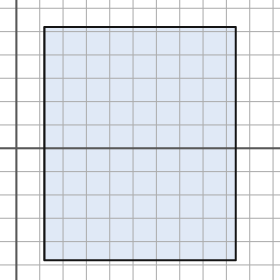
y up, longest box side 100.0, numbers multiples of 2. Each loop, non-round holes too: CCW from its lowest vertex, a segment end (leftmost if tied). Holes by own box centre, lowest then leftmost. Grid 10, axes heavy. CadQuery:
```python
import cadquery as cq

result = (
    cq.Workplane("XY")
    .moveTo(12.0, -48.0)
    .lineTo(94.0, -48.0)
    .lineTo(94.0, 52.0)
    .lineTo(12.0, 52.0)
    .close()
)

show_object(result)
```